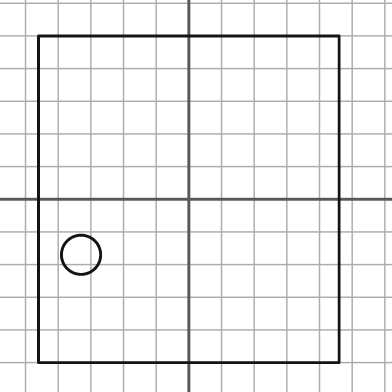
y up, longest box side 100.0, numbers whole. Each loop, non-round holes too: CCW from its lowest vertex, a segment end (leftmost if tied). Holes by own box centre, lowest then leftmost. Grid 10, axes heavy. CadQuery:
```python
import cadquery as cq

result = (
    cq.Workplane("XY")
    .moveTo(-46.0, -50.0)
    .lineTo(46.0, -50.0)
    .lineTo(46.0, 50.0)
    .lineTo(-46.0, 50.0)
    .close()
    .moveTo(-33.0, -17.0)
    .circle(6.0)
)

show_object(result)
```